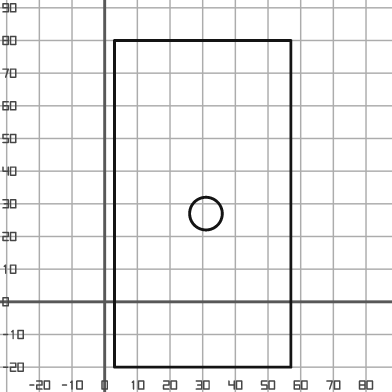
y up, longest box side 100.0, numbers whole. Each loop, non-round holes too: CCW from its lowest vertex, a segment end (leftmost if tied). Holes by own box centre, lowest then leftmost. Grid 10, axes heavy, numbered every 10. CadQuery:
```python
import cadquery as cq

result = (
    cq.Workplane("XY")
    .moveTo(3.0, -20.0)
    .lineTo(57.0, -20.0)
    .lineTo(57.0, 80.0)
    .lineTo(3.0, 80.0)
    .close()
    .moveTo(31.0, 27.0)
    .circle(5.0)
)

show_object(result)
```